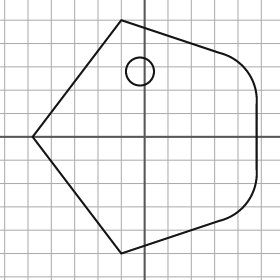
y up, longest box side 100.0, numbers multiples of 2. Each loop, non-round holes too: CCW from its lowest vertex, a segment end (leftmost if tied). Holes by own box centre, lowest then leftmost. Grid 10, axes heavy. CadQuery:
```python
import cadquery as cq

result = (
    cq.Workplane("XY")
    .moveTo(-10.0, -50.0)
    .lineTo(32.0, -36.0)
    .threePointArc((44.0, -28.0), (48.0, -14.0))
    .lineTo(48.0, 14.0)
    .threePointArc((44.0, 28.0), (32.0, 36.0))
    .lineTo(-10.0, 50.0)
    .lineTo(-48.0, 0.0)
    .close()
    .moveTo(-2.0, 28.0)
    .circle(6.0)
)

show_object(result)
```